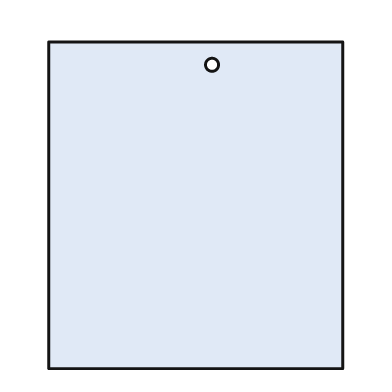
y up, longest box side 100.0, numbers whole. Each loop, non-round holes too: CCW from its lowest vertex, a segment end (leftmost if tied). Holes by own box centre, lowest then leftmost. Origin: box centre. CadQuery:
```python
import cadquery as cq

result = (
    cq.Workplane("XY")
    .moveTo(-45.0, -50.0)
    .lineTo(45.0, -50.0)
    .lineTo(45.0, 50.0)
    .lineTo(-45.0, 50.0)
    .close()
    .moveTo(5.0, 43.0)
    .circle(2.0)
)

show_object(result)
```